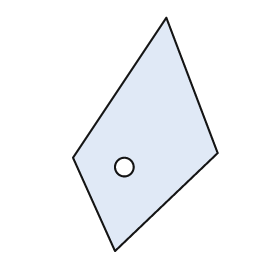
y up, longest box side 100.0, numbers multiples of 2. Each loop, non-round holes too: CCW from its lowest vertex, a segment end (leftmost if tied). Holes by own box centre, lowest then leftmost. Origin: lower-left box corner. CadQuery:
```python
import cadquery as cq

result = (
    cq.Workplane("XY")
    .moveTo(18.0, 0.0)
    .lineTo(62.0, 42.0)
    .lineTo(40.0, 100.0)
    .lineTo(0.0, 40.0)
    .close()
    .moveTo(22.0, 36.0)
    .circle(4.0)
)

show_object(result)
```